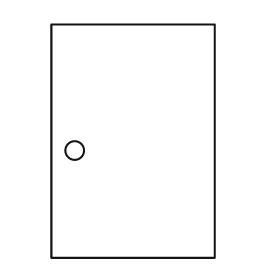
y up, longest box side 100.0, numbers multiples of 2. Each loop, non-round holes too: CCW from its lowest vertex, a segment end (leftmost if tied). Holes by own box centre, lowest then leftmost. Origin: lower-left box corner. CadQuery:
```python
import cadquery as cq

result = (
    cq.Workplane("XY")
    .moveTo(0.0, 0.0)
    .lineTo(70.0, 0.0)
    .lineTo(70.0, 100.0)
    .lineTo(0.0, 100.0)
    .close()
    .moveTo(10.0, 46.0)
    .circle(4.0)
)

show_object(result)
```